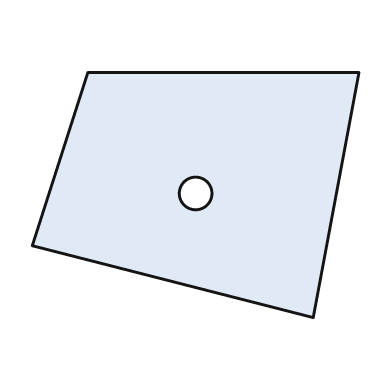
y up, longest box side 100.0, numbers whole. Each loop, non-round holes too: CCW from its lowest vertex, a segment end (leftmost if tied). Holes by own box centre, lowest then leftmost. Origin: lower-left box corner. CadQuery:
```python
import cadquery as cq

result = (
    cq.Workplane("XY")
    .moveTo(86.0, 0.0)
    .lineTo(100.0, 75.0)
    .lineTo(17.0, 75.0)
    .lineTo(0.0, 22.0)
    .close()
    .moveTo(50.0, 38.0)
    .circle(5.0)
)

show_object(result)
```